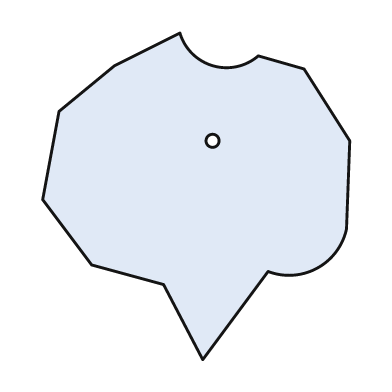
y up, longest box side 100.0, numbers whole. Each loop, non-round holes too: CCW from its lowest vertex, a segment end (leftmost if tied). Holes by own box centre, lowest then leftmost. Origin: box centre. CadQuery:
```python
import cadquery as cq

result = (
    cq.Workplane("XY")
    .moveTo(2.0, -50.0)
    .lineTo(22.0, -23.0)
    .threePointArc((37.0, -22.0), (46.0, -10.0))
    .lineTo(47.0, 17.0)
    .lineTo(33.0, 39.0)
    .lineTo(19.0, 43.0)
    .threePointArc((5.0, 40.0), (-5.0, 50.0))
    .lineTo(-25.0, 40.0)
    .lineTo(-42.0, 26.0)
    .lineTo(-47.0, -1.0)
    .lineTo(-32.0, -21.0)
    .lineTo(-10.0, -27.0)
    .close()
    .moveTo(5.0, 17.0)
    .circle(2.0)
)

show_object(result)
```